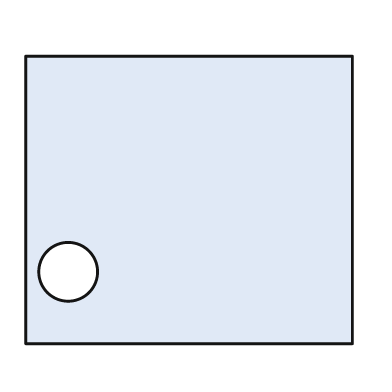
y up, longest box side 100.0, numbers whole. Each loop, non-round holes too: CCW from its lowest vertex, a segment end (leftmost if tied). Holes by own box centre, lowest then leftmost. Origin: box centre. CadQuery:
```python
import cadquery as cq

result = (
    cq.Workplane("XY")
    .moveTo(-50.0, -44.0)
    .lineTo(50.0, -44.0)
    .lineTo(50.0, 44.0)
    .lineTo(-50.0, 44.0)
    .close()
    .moveTo(-37.0, -22.0)
    .circle(9.0)
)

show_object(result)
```